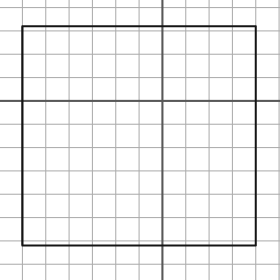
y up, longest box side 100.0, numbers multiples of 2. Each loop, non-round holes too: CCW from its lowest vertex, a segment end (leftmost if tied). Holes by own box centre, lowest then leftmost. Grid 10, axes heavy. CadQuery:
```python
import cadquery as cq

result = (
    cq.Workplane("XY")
    .moveTo(-60.0, -62.0)
    .lineTo(40.0, -62.0)
    .lineTo(40.0, 32.0)
    .lineTo(-60.0, 32.0)
    .close()
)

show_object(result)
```